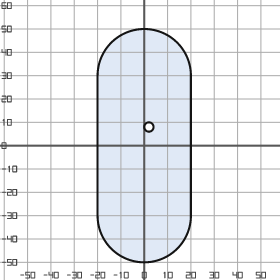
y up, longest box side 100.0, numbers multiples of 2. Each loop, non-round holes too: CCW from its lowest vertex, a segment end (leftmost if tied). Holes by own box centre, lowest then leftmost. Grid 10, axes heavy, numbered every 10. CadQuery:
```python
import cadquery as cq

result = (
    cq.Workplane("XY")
    .moveTo(-20.0, -30.0)
    .threePointArc((0.0, -50.0), (20.0, -30.0))
    .lineTo(20.0, 30.0)
    .threePointArc((0.0, 50.0), (-20.0, 30.0))
    .close()
    .moveTo(2.0, 8.0)
    .circle(2.0)
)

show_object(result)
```